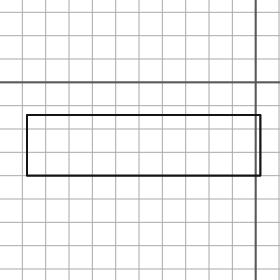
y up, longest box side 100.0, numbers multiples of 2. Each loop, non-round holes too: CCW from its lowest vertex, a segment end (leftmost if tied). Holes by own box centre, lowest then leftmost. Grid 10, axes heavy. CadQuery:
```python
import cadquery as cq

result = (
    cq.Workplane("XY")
    .moveTo(-98.0, -40.0)
    .lineTo(2.0, -40.0)
    .lineTo(2.0, -14.0)
    .lineTo(-98.0, -14.0)
    .close()
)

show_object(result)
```